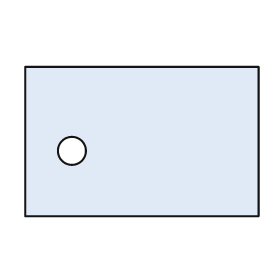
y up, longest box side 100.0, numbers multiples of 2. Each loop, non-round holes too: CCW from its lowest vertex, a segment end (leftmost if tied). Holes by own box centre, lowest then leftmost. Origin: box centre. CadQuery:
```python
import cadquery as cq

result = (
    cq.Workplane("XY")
    .moveTo(-50.0, -32.0)
    .lineTo(50.0, -32.0)
    .lineTo(50.0, 32.0)
    .lineTo(-50.0, 32.0)
    .close()
    .moveTo(-30.0, -4.0)
    .circle(6.0)
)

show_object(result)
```